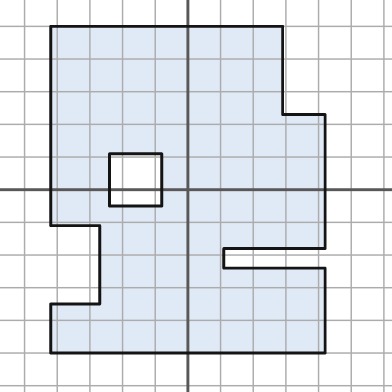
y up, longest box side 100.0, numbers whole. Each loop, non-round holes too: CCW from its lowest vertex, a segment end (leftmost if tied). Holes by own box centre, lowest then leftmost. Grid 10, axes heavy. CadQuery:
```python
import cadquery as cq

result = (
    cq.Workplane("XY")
    .moveTo(-42.0, -50.0)
    .lineTo(42.0, -50.0)
    .lineTo(42.0, -24.0)
    .lineTo(11.0, -24.0)
    .lineTo(11.0, -18.0)
    .lineTo(42.0, -18.0)
    .lineTo(42.0, 23.0)
    .lineTo(29.0, 23.0)
    .lineTo(29.0, 50.0)
    .lineTo(-42.0, 50.0)
    .lineTo(-42.0, -11.0)
    .lineTo(-27.0, -11.0)
    .lineTo(-27.0, -35.0)
    .lineTo(-42.0, -35.0)
    .close()
    .moveTo(-24.0, -5.0)
    .lineTo(-8.0, -5.0)
    .lineTo(-8.0, 11.0)
    .lineTo(-24.0, 11.0)
    .close()
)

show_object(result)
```